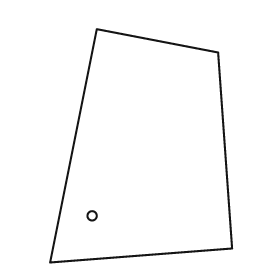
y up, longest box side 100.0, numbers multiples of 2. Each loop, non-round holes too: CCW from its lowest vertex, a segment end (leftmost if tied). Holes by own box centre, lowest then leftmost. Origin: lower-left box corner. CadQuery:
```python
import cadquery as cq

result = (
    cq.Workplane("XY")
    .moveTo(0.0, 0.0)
    .lineTo(78.0, 6.0)
    .lineTo(72.0, 90.0)
    .lineTo(20.0, 100.0)
    .close()
    .moveTo(18.0, 20.0)
    .circle(2.0)
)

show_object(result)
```